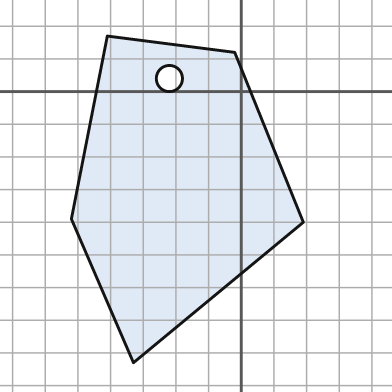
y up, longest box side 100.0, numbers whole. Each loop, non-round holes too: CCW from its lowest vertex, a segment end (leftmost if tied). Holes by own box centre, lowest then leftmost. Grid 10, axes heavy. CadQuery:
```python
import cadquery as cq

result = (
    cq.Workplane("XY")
    .moveTo(-33.0, -83.0)
    .lineTo(19.0, -40.0)
    .lineTo(-2.0, 12.0)
    .lineTo(-41.0, 17.0)
    .lineTo(-52.0, -39.0)
    .close()
    .moveTo(-22.0, 4.0)
    .circle(4.0)
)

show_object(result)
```